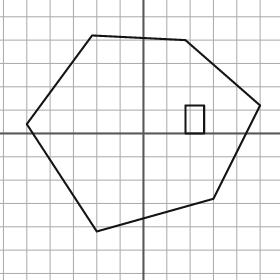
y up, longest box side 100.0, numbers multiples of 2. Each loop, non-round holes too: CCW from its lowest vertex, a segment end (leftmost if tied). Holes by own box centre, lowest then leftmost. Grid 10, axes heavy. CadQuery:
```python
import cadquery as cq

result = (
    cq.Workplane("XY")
    .moveTo(-20.0, -42.0)
    .lineTo(30.0, -28.0)
    .lineTo(50.0, 12.0)
    .lineTo(18.0, 40.0)
    .lineTo(-22.0, 42.0)
    .lineTo(-50.0, 4.0)
    .close()
    .moveTo(18.0, 0.0)
    .lineTo(26.0, 0.0)
    .lineTo(26.0, 12.0)
    .lineTo(18.0, 12.0)
    .close()
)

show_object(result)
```